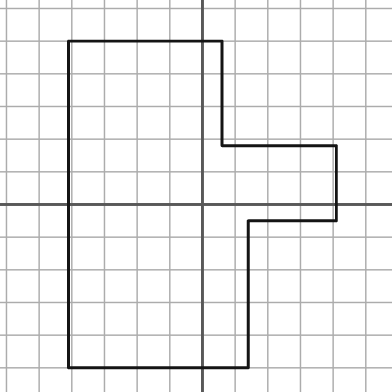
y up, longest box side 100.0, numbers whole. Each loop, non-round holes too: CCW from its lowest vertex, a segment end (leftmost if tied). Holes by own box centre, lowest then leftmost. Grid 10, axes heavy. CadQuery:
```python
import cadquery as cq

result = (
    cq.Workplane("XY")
    .moveTo(-41.0, -50.0)
    .lineTo(14.0, -50.0)
    .lineTo(14.0, -5.0)
    .lineTo(41.0, -5.0)
    .lineTo(41.0, 18.0)
    .lineTo(6.0, 18.0)
    .lineTo(6.0, 50.0)
    .lineTo(-41.0, 50.0)
    .close()
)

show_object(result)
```